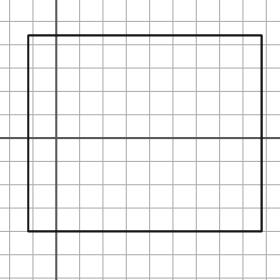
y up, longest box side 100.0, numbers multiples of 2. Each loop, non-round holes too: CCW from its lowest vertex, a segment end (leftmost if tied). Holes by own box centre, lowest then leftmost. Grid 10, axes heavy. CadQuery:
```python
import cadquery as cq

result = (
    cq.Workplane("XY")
    .moveTo(-12.0, -40.0)
    .lineTo(88.0, -40.0)
    .lineTo(88.0, 44.0)
    .lineTo(-12.0, 44.0)
    .close()
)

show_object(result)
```